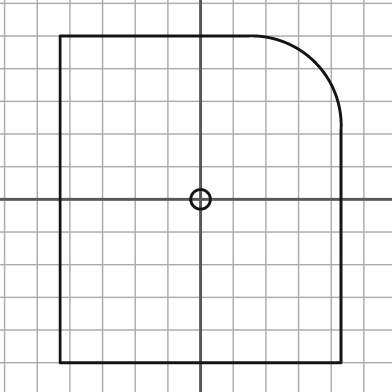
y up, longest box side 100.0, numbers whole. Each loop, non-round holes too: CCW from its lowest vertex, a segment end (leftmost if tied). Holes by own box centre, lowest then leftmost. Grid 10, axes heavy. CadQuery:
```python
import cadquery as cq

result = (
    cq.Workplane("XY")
    .moveTo(-43.0, -50.0)
    .lineTo(43.0, -50.0)
    .lineTo(43.0, 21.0)
    .threePointArc((35.0, 42.0), (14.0, 50.0))
    .lineTo(-43.0, 50.0)
    .close()
    .moveTo(0.0, 0.0)
    .circle(3.0)
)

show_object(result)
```